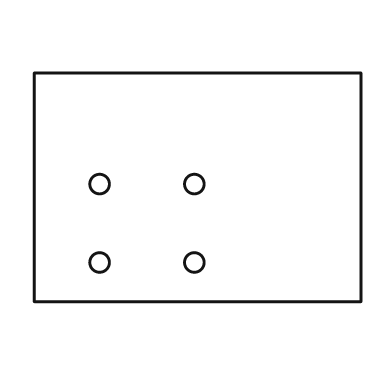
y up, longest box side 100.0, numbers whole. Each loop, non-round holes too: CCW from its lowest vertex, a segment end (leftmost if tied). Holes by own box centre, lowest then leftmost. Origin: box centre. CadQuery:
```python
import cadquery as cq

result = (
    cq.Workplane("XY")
    .moveTo(-50.0, -35.0)
    .lineTo(50.0, -35.0)
    .lineTo(50.0, 35.0)
    .lineTo(-50.0, 35.0)
    .close()
    .moveTo(-30.0, -23.0)
    .circle(3.0)
    .moveTo(-1.0, -23.0)
    .circle(3.0)
    .moveTo(-30.0, 1.0)
    .circle(3.0)
    .moveTo(-1.0, 1.0)
    .circle(3.0)
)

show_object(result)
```